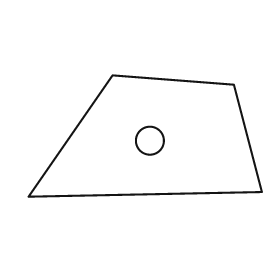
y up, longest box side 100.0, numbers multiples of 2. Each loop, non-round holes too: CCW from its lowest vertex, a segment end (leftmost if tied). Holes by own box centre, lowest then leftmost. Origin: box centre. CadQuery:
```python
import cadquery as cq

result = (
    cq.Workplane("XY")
    .moveTo(-50.0, -26.0)
    .lineTo(50.0, -24.0)
    .lineTo(38.0, 22.0)
    .lineTo(-14.0, 26.0)
    .close()
    .moveTo(2.0, -2.0)
    .circle(6.0)
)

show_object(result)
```